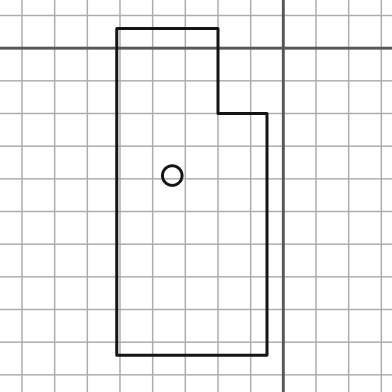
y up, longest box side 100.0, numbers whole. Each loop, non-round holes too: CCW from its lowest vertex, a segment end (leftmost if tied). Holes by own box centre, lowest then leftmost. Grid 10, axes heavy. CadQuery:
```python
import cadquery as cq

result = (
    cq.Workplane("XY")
    .moveTo(-51.0, -94.0)
    .lineTo(-5.0, -94.0)
    .lineTo(-5.0, -20.0)
    .lineTo(-20.0, -20.0)
    .lineTo(-20.0, 6.0)
    .lineTo(-51.0, 6.0)
    .close()
    .moveTo(-34.0, -39.0)
    .circle(3.0)
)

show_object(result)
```